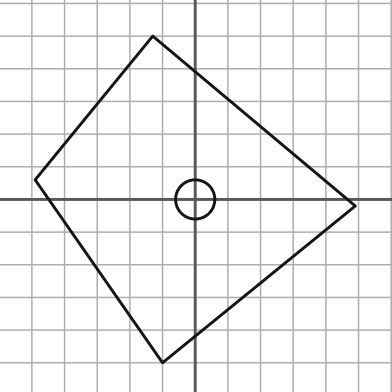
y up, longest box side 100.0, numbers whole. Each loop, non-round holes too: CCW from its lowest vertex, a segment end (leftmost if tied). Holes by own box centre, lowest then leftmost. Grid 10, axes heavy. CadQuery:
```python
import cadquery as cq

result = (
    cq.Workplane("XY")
    .moveTo(-10.0, -50.0)
    .lineTo(49.0, -2.0)
    .lineTo(-13.0, 50.0)
    .lineTo(-49.0, 6.0)
    .close()
    .moveTo(0.0, 0.0)
    .circle(6.0)
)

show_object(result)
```